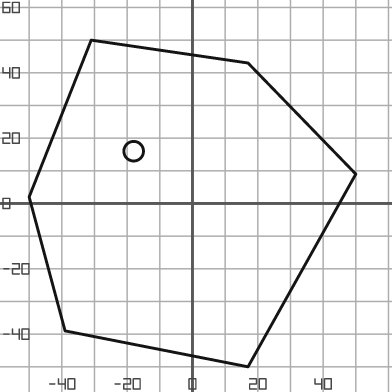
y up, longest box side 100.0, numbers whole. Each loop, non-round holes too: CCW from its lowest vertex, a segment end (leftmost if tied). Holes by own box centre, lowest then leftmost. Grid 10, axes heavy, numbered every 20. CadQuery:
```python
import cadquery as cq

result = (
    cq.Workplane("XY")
    .moveTo(17.0, -50.0)
    .lineTo(50.0, 9.0)
    .lineTo(17.0, 43.0)
    .lineTo(-31.0, 50.0)
    .lineTo(-50.0, 2.0)
    .lineTo(-39.0, -39.0)
    .close()
    .moveTo(-18.0, 16.0)
    .circle(3.0)
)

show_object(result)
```